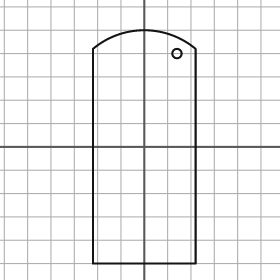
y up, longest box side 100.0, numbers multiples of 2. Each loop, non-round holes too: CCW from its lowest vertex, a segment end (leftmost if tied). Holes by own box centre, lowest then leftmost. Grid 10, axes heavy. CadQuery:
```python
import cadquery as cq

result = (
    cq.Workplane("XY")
    .moveTo(-22.0, -50.0)
    .lineTo(22.0, -50.0)
    .lineTo(22.0, 42.0)
    .threePointArc((0.0, 50.0), (-22.0, 42.0))
    .close()
    .moveTo(14.0, 40.0)
    .circle(2.0)
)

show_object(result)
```